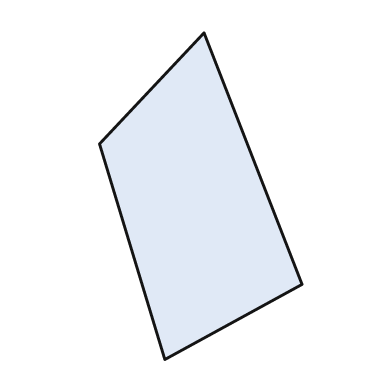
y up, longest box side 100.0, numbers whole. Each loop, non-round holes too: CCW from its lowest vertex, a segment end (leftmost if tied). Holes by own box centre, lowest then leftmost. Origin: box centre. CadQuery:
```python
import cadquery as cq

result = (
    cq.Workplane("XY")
    .moveTo(-11.0, -50.0)
    .lineTo(31.0, -27.0)
    .lineTo(1.0, 50.0)
    .lineTo(-31.0, 16.0)
    .close()
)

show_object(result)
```